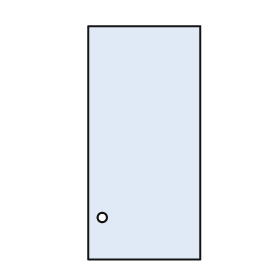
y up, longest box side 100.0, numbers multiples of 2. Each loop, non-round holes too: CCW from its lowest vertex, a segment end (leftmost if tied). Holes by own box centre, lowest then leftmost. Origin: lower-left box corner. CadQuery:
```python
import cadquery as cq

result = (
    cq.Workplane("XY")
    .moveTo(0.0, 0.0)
    .lineTo(48.0, 0.0)
    .lineTo(48.0, 100.0)
    .lineTo(0.0, 100.0)
    .close()
    .moveTo(6.0, 18.0)
    .circle(2.0)
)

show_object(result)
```